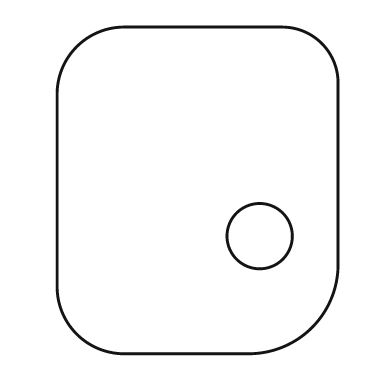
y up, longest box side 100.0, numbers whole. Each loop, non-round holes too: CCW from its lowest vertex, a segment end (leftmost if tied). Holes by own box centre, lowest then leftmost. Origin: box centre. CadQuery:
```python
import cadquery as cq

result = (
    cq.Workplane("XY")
    .moveTo(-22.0, -50.0)
    .lineTo(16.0, -50.0)
    .threePointArc((35.0, -42.0), (43.0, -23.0))
    .lineTo(43.0, 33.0)
    .threePointArc((38.0, 45.0), (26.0, 50.0))
    .lineTo(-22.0, 50.0)
    .threePointArc((-37.0, 44.0), (-43.0, 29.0))
    .lineTo(-43.0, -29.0)
    .threePointArc((-37.0, -44.0), (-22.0, -50.0))
    .close()
    .moveTo(19.0, -14.0)
    .circle(10.0)
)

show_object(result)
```